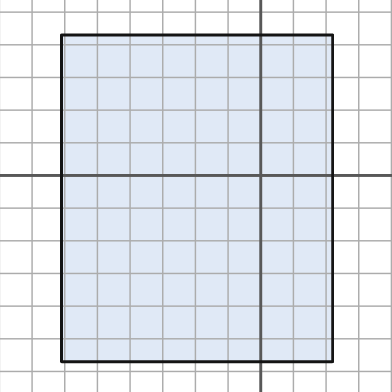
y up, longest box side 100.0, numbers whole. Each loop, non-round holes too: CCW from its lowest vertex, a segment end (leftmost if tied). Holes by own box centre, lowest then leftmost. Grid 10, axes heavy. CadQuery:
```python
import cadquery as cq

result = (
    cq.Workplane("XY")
    .moveTo(-61.0, -57.0)
    .lineTo(22.0, -57.0)
    .lineTo(22.0, 43.0)
    .lineTo(-61.0, 43.0)
    .close()
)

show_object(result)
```